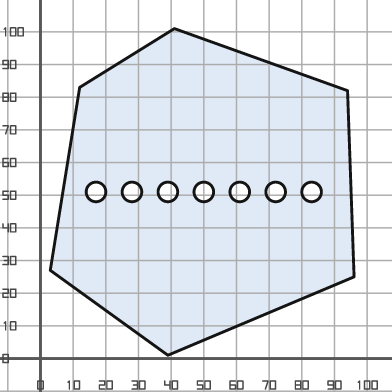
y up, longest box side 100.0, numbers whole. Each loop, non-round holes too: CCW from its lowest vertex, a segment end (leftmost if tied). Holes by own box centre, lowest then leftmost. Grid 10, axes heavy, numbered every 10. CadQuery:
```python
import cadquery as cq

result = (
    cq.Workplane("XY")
    .moveTo(39.0, 1.0)
    .lineTo(96.0, 25.0)
    .lineTo(94.0, 82.0)
    .lineTo(41.0, 101.0)
    .lineTo(12.0, 83.0)
    .lineTo(3.0, 27.0)
    .close()
    .moveTo(17.0, 51.0)
    .circle(3.0)
    .moveTo(28.0, 51.0)
    .circle(3.0)
    .moveTo(39.0, 51.0)
    .circle(3.0)
    .moveTo(50.0, 51.0)
    .circle(3.0)
    .moveTo(61.0, 51.0)
    .circle(3.0)
    .moveTo(72.0, 51.0)
    .circle(3.0)
    .moveTo(83.0, 51.0)
    .circle(3.0)
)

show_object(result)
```